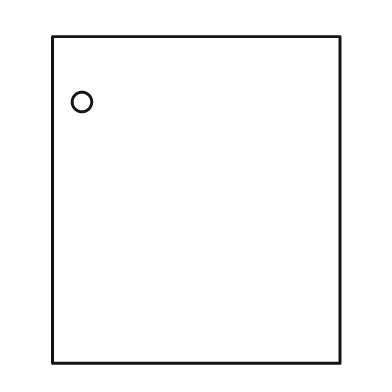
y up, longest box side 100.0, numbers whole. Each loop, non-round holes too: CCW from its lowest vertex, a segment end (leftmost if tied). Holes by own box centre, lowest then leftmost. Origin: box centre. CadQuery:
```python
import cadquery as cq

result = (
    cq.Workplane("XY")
    .moveTo(-44.0, -50.0)
    .lineTo(44.0, -50.0)
    .lineTo(44.0, 50.0)
    .lineTo(-44.0, 50.0)
    .close()
    .moveTo(-35.0, 30.0)
    .circle(3.0)
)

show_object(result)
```